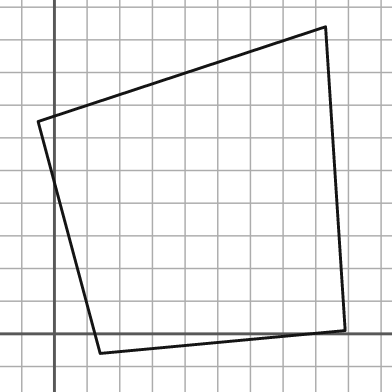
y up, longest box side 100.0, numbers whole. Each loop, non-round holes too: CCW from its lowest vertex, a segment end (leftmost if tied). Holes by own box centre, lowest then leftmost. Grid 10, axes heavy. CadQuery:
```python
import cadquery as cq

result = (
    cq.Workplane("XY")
    .moveTo(14.0, -6.0)
    .lineTo(89.0, 1.0)
    .lineTo(83.0, 94.0)
    .lineTo(-5.0, 65.0)
    .close()
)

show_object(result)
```